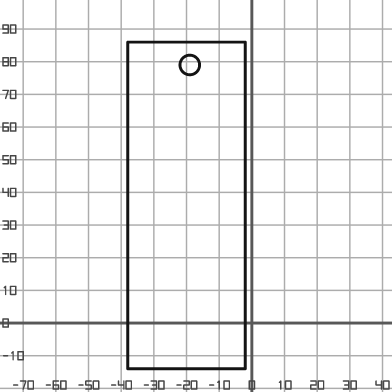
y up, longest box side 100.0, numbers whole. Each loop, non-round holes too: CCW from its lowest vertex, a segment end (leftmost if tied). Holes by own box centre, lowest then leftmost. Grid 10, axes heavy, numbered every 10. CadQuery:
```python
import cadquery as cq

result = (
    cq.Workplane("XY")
    .moveTo(-38.0, -14.0)
    .lineTo(-2.0, -14.0)
    .lineTo(-2.0, 86.0)
    .lineTo(-38.0, 86.0)
    .close()
    .moveTo(-19.0, 79.0)
    .circle(3.0)
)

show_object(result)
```